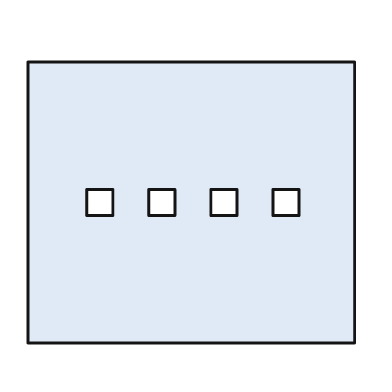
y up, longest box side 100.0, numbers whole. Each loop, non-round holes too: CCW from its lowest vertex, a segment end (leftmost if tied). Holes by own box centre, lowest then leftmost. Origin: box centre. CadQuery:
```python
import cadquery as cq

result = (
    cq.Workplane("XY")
    .moveTo(-50.0, -43.0)
    .lineTo(50.0, -43.0)
    .lineTo(50.0, 43.0)
    .lineTo(-50.0, 43.0)
    .close()
    .moveTo(-32.0, -4.0)
    .lineTo(-24.0, -4.0)
    .lineTo(-24.0, 4.0)
    .lineTo(-32.0, 4.0)
    .close()
    .moveTo(-13.0, -4.0)
    .lineTo(-5.0, -4.0)
    .lineTo(-5.0, 4.0)
    .lineTo(-13.0, 4.0)
    .close()
    .moveTo(6.0, -4.0)
    .lineTo(14.0, -4.0)
    .lineTo(14.0, 4.0)
    .lineTo(6.0, 4.0)
    .close()
    .moveTo(25.0, -4.0)
    .lineTo(33.0, -4.0)
    .lineTo(33.0, 4.0)
    .lineTo(25.0, 4.0)
    .close()
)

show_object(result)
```